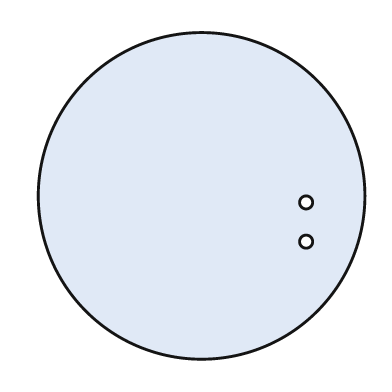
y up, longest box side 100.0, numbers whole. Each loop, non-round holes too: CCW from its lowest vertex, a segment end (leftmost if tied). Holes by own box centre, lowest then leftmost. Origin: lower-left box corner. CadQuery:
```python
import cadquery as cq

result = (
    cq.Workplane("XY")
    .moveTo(50.0, 50.0)
    .circle(50.0)
    .moveTo(82.0, 36.0)
    .circle(2.0)
    .moveTo(82.0, 48.0)
    .circle(2.0)
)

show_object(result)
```